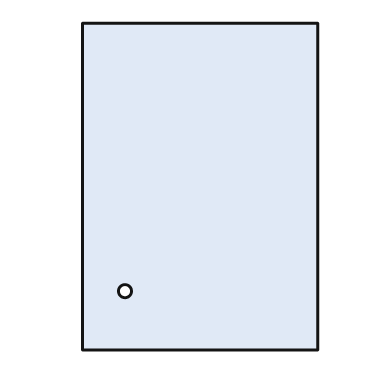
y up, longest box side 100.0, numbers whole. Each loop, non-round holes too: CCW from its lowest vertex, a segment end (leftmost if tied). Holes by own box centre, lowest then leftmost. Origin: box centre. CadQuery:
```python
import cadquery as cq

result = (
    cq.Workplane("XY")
    .moveTo(-36.0, -50.0)
    .lineTo(36.0, -50.0)
    .lineTo(36.0, 50.0)
    .lineTo(-36.0, 50.0)
    .close()
    .moveTo(-23.0, -32.0)
    .circle(2.0)
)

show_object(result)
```